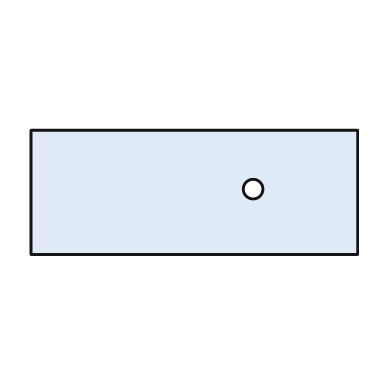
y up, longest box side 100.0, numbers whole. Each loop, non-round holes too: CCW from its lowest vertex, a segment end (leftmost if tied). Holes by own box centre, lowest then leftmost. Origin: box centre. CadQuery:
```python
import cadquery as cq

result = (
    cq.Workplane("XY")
    .moveTo(-50.0, -19.0)
    .lineTo(50.0, -19.0)
    .lineTo(50.0, 19.0)
    .lineTo(-50.0, 19.0)
    .close()
    .moveTo(18.0, 1.0)
    .circle(3.0)
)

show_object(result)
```